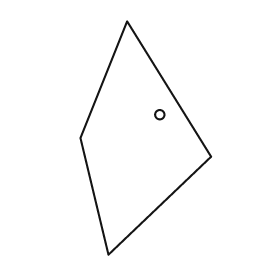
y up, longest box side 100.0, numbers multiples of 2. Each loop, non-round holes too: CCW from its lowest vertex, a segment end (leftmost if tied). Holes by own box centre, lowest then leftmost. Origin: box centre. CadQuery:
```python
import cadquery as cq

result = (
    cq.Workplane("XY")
    .moveTo(-16.0, -50.0)
    .lineTo(28.0, -8.0)
    .lineTo(-8.0, 50.0)
    .lineTo(-28.0, 0.0)
    .close()
    .moveTo(6.0, 10.0)
    .circle(2.0)
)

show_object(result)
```